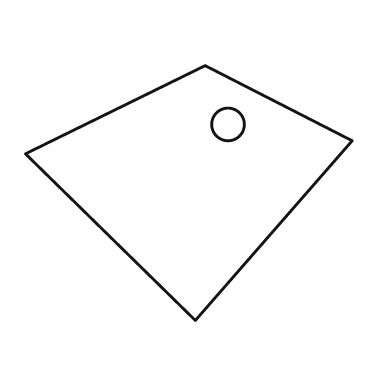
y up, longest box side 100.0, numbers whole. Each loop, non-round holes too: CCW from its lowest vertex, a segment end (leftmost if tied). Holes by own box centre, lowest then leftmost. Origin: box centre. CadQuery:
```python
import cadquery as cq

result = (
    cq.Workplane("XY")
    .moveTo(2.0, -39.0)
    .lineTo(50.0, 16.0)
    .lineTo(5.0, 39.0)
    .lineTo(-50.0, 12.0)
    .close()
    .moveTo(12.0, 21.0)
    .circle(5.0)
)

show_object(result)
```